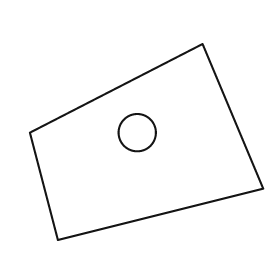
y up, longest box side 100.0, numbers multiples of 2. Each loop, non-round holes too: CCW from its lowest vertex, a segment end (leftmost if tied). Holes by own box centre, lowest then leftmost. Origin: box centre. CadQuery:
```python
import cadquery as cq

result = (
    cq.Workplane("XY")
    .moveTo(-38.0, -42.0)
    .lineTo(50.0, -20.0)
    .lineTo(24.0, 42.0)
    .lineTo(-50.0, 4.0)
    .close()
    .moveTo(-4.0, 4.0)
    .circle(8.0)
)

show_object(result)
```